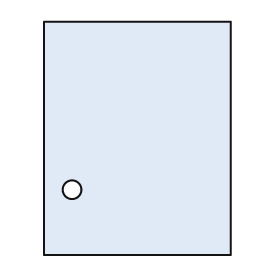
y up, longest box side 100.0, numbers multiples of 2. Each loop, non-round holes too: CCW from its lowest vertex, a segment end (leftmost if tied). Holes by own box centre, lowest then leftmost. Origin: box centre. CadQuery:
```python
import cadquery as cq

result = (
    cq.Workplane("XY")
    .moveTo(-40.0, -50.0)
    .lineTo(40.0, -50.0)
    .lineTo(40.0, 50.0)
    .lineTo(-40.0, 50.0)
    .close()
    .moveTo(-28.0, -22.0)
    .circle(4.0)
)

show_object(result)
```